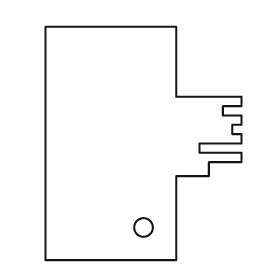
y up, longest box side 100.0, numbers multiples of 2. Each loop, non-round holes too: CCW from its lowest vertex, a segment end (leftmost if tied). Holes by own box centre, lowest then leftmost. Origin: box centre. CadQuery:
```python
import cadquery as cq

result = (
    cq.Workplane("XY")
    .moveTo(-42.0, -50.0)
    .lineTo(14.0, -50.0)
    .lineTo(14.0, -14.0)
    .lineTo(28.0, -14.0)
    .lineTo(28.0, -8.0)
    .lineTo(42.0, -8.0)
    .lineTo(42.0, -4.0)
    .lineTo(24.0, -4.0)
    .lineTo(24.0, 0.0)
    .lineTo(42.0, 0.0)
    .lineTo(42.0, 4.0)
    .lineTo(38.0, 4.0)
    .lineTo(38.0, 8.0)
    .lineTo(42.0, 8.0)
    .lineTo(42.0, 12.0)
    .lineTo(34.0, 12.0)
    .lineTo(34.0, 16.0)
    .lineTo(42.0, 16.0)
    .lineTo(42.0, 20.0)
    .lineTo(14.0, 20.0)
    .lineTo(14.0, 50.0)
    .lineTo(-42.0, 50.0)
    .close()
    .moveTo(0.0, -36.0)
    .circle(4.0)
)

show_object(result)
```